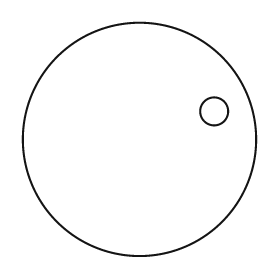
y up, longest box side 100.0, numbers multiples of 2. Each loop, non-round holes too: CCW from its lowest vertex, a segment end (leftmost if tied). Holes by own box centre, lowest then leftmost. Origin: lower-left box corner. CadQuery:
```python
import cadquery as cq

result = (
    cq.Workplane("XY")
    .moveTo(50.0, 50.0)
    .circle(50.0)
    .moveTo(82.0, 62.0)
    .circle(6.0)
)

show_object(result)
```